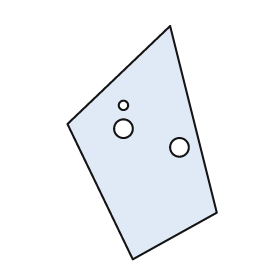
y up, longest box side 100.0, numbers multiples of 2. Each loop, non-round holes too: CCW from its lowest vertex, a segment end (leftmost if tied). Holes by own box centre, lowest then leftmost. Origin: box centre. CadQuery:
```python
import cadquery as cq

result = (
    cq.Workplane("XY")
    .moveTo(-4.0, -50.0)
    .lineTo(32.0, -30.0)
    .lineTo(12.0, 50.0)
    .lineTo(-32.0, 8.0)
    .close()
    .moveTo(16.0, -2.0)
    .circle(4.0)
    .moveTo(-8.0, 6.0)
    .circle(4.0)
    .moveTo(-8.0, 16.0)
    .circle(2.0)
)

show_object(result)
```